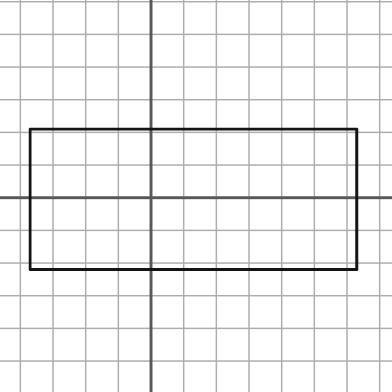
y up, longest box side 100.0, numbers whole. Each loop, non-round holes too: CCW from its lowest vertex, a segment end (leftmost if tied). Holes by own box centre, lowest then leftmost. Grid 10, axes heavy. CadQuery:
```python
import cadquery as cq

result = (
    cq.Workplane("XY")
    .moveTo(-37.0, -22.0)
    .lineTo(63.0, -22.0)
    .lineTo(63.0, 21.0)
    .lineTo(-37.0, 21.0)
    .close()
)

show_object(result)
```